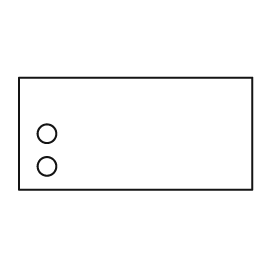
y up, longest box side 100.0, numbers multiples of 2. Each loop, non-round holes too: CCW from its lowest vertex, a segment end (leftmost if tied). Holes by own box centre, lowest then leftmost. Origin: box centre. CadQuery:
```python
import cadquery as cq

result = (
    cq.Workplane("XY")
    .moveTo(-50.0, -24.0)
    .lineTo(50.0, -24.0)
    .lineTo(50.0, 24.0)
    .lineTo(-50.0, 24.0)
    .close()
    .moveTo(-38.0, -14.0)
    .circle(4.0)
    .moveTo(-38.0, 0.0)
    .circle(4.0)
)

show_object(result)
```